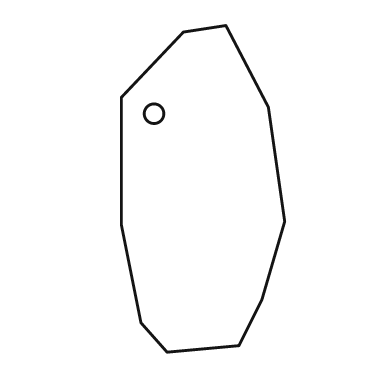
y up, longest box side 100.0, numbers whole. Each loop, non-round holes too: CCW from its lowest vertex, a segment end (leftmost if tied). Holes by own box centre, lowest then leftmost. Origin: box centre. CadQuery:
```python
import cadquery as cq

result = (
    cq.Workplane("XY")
    .moveTo(-11.0, -50.0)
    .lineTo(11.0, -48.0)
    .lineTo(18.0, -34.0)
    .lineTo(25.0, -10.0)
    .lineTo(20.0, 25.0)
    .lineTo(7.0, 50.0)
    .lineTo(-6.0, 48.0)
    .lineTo(-25.0, 28.0)
    .lineTo(-25.0, -11.0)
    .lineTo(-19.0, -41.0)
    .close()
    .moveTo(-15.0, 23.0)
    .circle(3.0)
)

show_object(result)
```